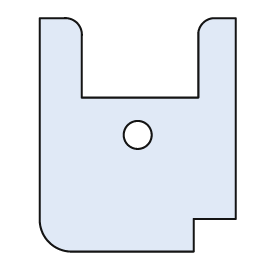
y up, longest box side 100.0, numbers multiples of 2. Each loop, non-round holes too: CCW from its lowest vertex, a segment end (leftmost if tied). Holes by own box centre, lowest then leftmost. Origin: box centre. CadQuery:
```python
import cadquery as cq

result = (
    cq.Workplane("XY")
    .moveTo(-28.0, -50.0)
    .lineTo(24.0, -50.0)
    .lineTo(24.0, -36.0)
    .lineTo(42.0, -36.0)
    .lineTo(42.0, 50.0)
    .lineTo(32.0, 50.0)
    .threePointArc((28.0, 48.0), (26.0, 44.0))
    .lineTo(26.0, 16.0)
    .lineTo(-24.0, 16.0)
    .lineTo(-24.0, 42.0)
    .threePointArc((-26.0, 48.0), (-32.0, 50.0))
    .lineTo(-42.0, 50.0)
    .lineTo(-42.0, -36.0)
    .threePointArc((-38.0, -46.0), (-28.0, -50.0))
    .close()
    .moveTo(0.0, 0.0)
    .circle(6.0)
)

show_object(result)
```